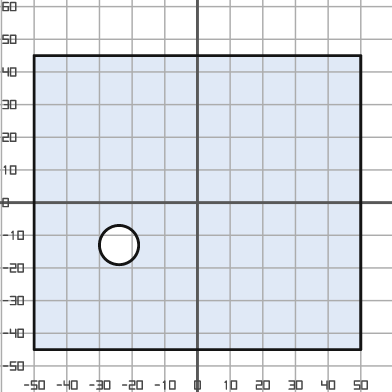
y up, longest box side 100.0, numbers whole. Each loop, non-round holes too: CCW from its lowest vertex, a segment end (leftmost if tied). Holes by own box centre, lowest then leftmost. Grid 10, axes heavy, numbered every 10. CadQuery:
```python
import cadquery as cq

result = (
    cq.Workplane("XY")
    .moveTo(-50.0, -45.0)
    .lineTo(50.0, -45.0)
    .lineTo(50.0, 45.0)
    .lineTo(-50.0, 45.0)
    .close()
    .moveTo(-24.0, -13.0)
    .circle(6.0)
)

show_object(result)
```